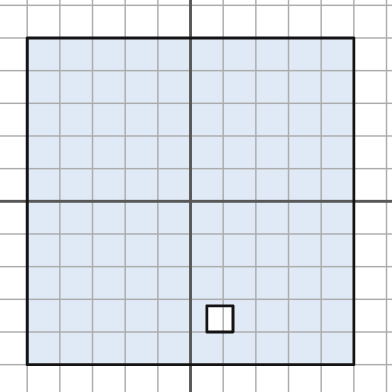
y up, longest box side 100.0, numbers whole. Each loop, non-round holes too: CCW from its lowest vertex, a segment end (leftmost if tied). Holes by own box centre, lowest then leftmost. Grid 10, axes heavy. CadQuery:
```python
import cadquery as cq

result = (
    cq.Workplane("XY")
    .moveTo(-50.0, -50.0)
    .lineTo(50.0, -50.0)
    .lineTo(50.0, 50.0)
    .lineTo(-50.0, 50.0)
    .close()
    .moveTo(5.0, -40.0)
    .lineTo(13.0, -40.0)
    .lineTo(13.0, -32.0)
    .lineTo(5.0, -32.0)
    .close()
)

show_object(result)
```